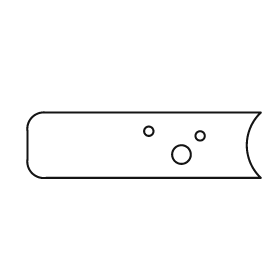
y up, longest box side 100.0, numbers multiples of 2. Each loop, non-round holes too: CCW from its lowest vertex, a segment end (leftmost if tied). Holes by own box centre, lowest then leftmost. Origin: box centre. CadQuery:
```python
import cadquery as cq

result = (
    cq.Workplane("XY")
    .moveTo(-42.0, -14.0)
    .lineTo(50.0, -14.0)
    .threePointArc((44.0, 0.0), (50.0, 14.0))
    .lineTo(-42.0, 14.0)
    .threePointArc((-48.0, 12.0), (-50.0, 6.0))
    .lineTo(-50.0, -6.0)
    .threePointArc((-48.0, -12.0), (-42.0, -14.0))
    .close()
    .moveTo(16.0, -4.0)
    .circle(4.0)
    .moveTo(24.0, 4.0)
    .circle(2.0)
    .moveTo(2.0, 6.0)
    .circle(2.0)
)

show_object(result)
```